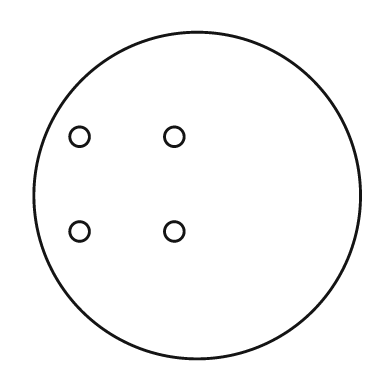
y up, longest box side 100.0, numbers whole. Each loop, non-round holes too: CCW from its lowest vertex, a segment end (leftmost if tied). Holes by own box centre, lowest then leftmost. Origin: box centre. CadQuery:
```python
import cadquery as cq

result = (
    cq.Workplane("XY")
    .moveTo(0.0, 0.0)
    .circle(50.0)
    .moveTo(-36.0, -11.0)
    .circle(3.0)
    .moveTo(-7.0, -11.0)
    .circle(3.0)
    .moveTo(-36.0, 18.0)
    .circle(3.0)
    .moveTo(-7.0, 18.0)
    .circle(3.0)
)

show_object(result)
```